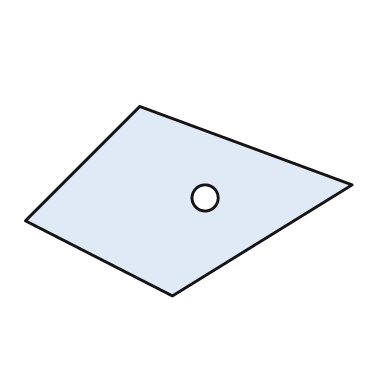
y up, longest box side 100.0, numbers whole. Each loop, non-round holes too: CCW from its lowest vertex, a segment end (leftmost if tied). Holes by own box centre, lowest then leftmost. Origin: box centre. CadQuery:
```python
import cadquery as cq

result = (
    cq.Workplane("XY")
    .moveTo(-5.0, -29.0)
    .lineTo(50.0, 5.0)
    .lineTo(-15.0, 29.0)
    .lineTo(-50.0, -6.0)
    .close()
    .moveTo(5.0, 1.0)
    .circle(4.0)
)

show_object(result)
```